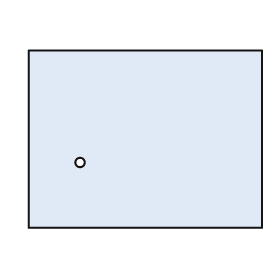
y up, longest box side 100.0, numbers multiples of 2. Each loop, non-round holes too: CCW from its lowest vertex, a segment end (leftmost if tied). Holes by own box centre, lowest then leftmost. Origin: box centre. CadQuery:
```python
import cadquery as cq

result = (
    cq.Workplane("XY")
    .moveTo(-50.0, -38.0)
    .lineTo(50.0, -38.0)
    .lineTo(50.0, 38.0)
    .lineTo(-50.0, 38.0)
    .close()
    .moveTo(-28.0, -10.0)
    .circle(2.0)
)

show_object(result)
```